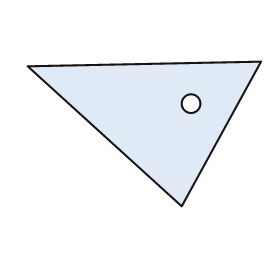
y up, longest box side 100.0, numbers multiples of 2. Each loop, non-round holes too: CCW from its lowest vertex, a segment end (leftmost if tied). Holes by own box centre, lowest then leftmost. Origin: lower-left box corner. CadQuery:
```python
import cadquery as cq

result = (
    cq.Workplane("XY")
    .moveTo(66.0, 0.0)
    .lineTo(100.0, 62.0)
    .lineTo(0.0, 60.0)
    .close()
    .moveTo(70.0, 44.0)
    .circle(4.0)
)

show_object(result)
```